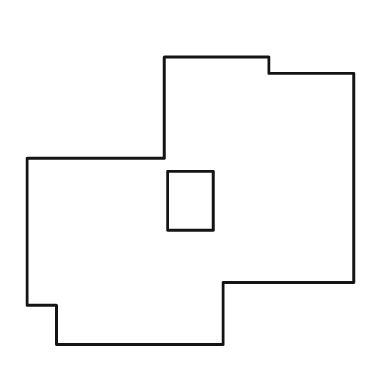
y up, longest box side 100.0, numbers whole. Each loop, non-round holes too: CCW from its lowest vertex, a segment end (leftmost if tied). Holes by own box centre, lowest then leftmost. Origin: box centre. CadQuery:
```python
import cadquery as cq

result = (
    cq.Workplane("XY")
    .moveTo(-41.0, -44.0)
    .lineTo(10.0, -44.0)
    .lineTo(10.0, -25.0)
    .lineTo(50.0, -25.0)
    .lineTo(50.0, 39.0)
    .lineTo(24.0, 39.0)
    .lineTo(24.0, 44.0)
    .lineTo(-8.0, 44.0)
    .lineTo(-8.0, 13.0)
    .lineTo(-50.0, 13.0)
    .lineTo(-50.0, -32.0)
    .lineTo(-41.0, -32.0)
    .close()
    .moveTo(-7.0, -9.0)
    .lineTo(7.0, -9.0)
    .lineTo(7.0, 9.0)
    .lineTo(-7.0, 9.0)
    .close()
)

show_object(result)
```